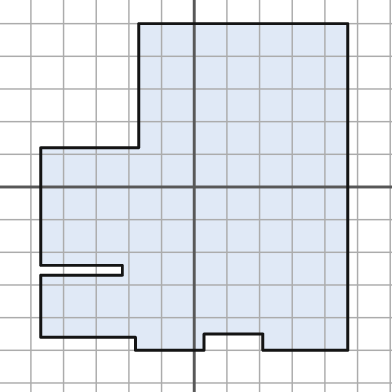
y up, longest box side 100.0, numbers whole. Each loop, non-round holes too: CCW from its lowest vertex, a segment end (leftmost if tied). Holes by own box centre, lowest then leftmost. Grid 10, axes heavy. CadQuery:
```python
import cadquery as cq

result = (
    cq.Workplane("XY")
    .moveTo(-18.0, -50.0)
    .lineTo(3.0, -50.0)
    .lineTo(3.0, -45.0)
    .lineTo(21.0, -45.0)
    .lineTo(21.0, -50.0)
    .lineTo(47.0, -50.0)
    .lineTo(47.0, 50.0)
    .lineTo(-17.0, 50.0)
    .lineTo(-17.0, 12.0)
    .lineTo(-47.0, 12.0)
    .lineTo(-47.0, -24.0)
    .lineTo(-22.0, -24.0)
    .lineTo(-22.0, -27.0)
    .lineTo(-47.0, -27.0)
    .lineTo(-47.0, -46.0)
    .lineTo(-18.0, -46.0)
    .close()
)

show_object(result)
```